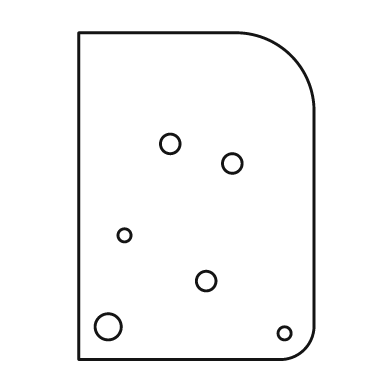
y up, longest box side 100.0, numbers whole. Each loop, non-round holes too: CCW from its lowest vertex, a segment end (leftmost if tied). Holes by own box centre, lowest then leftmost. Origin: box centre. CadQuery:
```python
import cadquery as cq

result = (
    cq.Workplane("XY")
    .moveTo(-36.0, -50.0)
    .lineTo(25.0, -50.0)
    .threePointArc((33.0, -47.0), (36.0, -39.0))
    .lineTo(36.0, 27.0)
    .threePointArc((29.0, 43.0), (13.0, 50.0))
    .lineTo(-36.0, 50.0)
    .close()
    .moveTo(27.0, -42.0)
    .circle(2.0)
    .moveTo(-27.0, -40.0)
    .circle(4.0)
    .moveTo(3.0, -26.0)
    .circle(3.0)
    .moveTo(-22.0, -12.0)
    .circle(2.0)
    .moveTo(11.0, 10.0)
    .circle(3.0)
    .moveTo(-8.0, 16.0)
    .circle(3.0)
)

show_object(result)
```